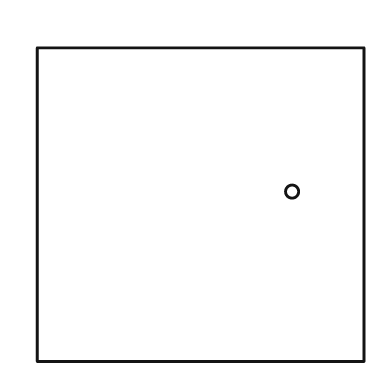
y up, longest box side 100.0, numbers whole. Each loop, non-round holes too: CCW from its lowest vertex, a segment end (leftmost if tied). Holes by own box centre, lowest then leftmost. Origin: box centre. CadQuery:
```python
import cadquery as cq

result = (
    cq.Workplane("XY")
    .moveTo(-50.0, -48.0)
    .lineTo(50.0, -48.0)
    .lineTo(50.0, 48.0)
    .lineTo(-50.0, 48.0)
    .close()
    .moveTo(28.0, 4.0)
    .circle(2.0)
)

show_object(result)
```